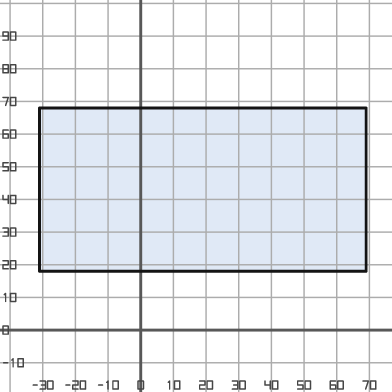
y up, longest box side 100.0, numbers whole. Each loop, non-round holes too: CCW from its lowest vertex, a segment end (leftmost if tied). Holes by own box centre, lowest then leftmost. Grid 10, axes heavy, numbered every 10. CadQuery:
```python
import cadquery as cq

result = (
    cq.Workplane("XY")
    .moveTo(-31.0, 18.0)
    .lineTo(69.0, 18.0)
    .lineTo(69.0, 68.0)
    .lineTo(-31.0, 68.0)
    .close()
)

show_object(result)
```